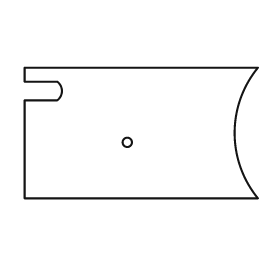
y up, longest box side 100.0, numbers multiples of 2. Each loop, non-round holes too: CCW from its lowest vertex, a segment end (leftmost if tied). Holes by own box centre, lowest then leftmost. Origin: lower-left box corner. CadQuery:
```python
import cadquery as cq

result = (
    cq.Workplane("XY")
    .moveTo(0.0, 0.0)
    .lineTo(100.0, 0.0)
    .threePointArc((90.0, 28.0), (100.0, 56.0))
    .lineTo(0.0, 56.0)
    .lineTo(0.0, 50.0)
    .lineTo(14.0, 50.0)
    .threePointArc((16.0, 46.0), (14.0, 42.0))
    .lineTo(0.0, 42.0)
    .close()
    .moveTo(44.0, 24.0)
    .circle(2.0)
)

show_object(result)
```